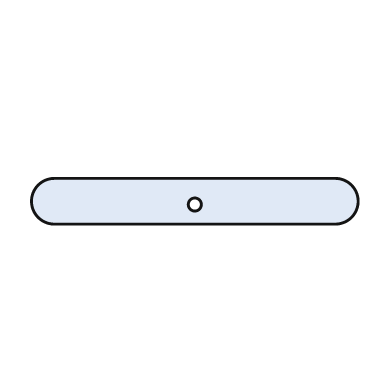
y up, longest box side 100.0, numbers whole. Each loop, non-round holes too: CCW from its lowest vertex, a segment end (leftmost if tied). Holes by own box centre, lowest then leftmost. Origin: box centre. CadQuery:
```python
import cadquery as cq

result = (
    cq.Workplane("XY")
    .moveTo(-43.0, -7.0)
    .lineTo(43.0, -7.0)
    .threePointArc((50.0, 0.0), (43.0, 7.0))
    .lineTo(-43.0, 7.0)
    .threePointArc((-50.0, 0.0), (-43.0, -7.0))
    .close()
    .moveTo(0.0, -1.0)
    .circle(2.0)
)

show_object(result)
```